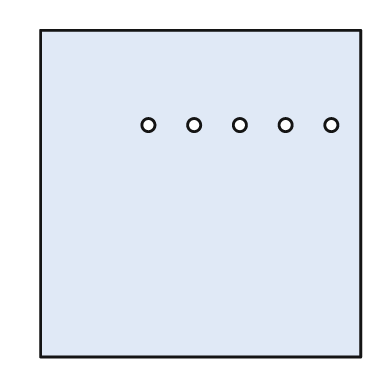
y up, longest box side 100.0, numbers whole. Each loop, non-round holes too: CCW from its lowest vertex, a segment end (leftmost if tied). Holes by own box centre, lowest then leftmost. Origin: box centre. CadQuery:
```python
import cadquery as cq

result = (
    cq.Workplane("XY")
    .moveTo(-49.0, -50.0)
    .lineTo(49.0, -50.0)
    .lineTo(49.0, 50.0)
    .lineTo(-49.0, 50.0)
    .close()
    .moveTo(-16.0, 21.0)
    .circle(2.0)
    .moveTo(-2.0, 21.0)
    .circle(2.0)
    .moveTo(12.0, 21.0)
    .circle(2.0)
    .moveTo(26.0, 21.0)
    .circle(2.0)
    .moveTo(40.0, 21.0)
    .circle(2.0)
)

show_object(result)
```